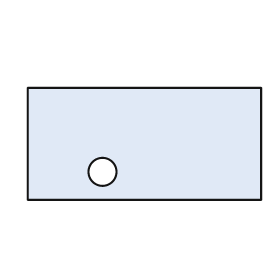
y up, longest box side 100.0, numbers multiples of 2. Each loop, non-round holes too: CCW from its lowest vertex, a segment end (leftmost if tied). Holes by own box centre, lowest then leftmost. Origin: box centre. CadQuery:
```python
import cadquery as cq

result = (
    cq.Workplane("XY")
    .moveTo(-50.0, -24.0)
    .lineTo(50.0, -24.0)
    .lineTo(50.0, 24.0)
    .lineTo(-50.0, 24.0)
    .close()
    .moveTo(-18.0, -12.0)
    .circle(6.0)
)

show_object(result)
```